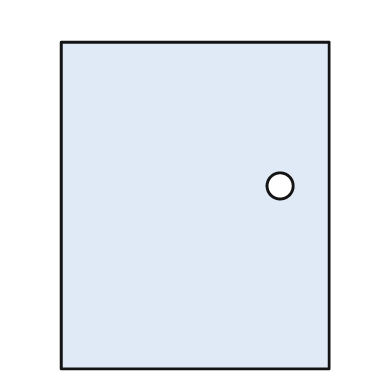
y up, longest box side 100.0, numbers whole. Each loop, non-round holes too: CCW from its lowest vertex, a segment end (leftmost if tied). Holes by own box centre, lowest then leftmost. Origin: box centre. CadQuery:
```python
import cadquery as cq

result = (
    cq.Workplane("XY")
    .moveTo(-41.0, -50.0)
    .lineTo(41.0, -50.0)
    .lineTo(41.0, 50.0)
    .lineTo(-41.0, 50.0)
    .close()
    .moveTo(26.0, 6.0)
    .circle(4.0)
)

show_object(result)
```